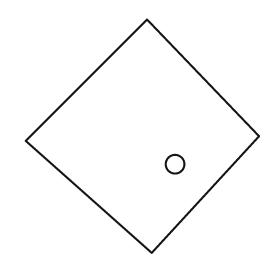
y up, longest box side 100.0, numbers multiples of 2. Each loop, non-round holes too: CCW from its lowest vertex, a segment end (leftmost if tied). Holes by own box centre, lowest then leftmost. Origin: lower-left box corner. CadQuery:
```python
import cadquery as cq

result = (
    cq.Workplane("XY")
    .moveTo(54.0, 0.0)
    .lineTo(100.0, 50.0)
    .lineTo(52.0, 100.0)
    .lineTo(0.0, 48.0)
    .close()
    .moveTo(64.0, 38.0)
    .circle(4.0)
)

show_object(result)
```